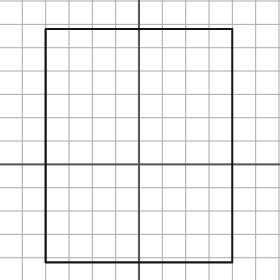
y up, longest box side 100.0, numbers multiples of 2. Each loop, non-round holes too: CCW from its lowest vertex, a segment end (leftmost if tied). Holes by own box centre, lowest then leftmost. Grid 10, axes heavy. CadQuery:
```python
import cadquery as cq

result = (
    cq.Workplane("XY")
    .moveTo(-40.0, -42.0)
    .lineTo(40.0, -42.0)
    .lineTo(40.0, 58.0)
    .lineTo(-40.0, 58.0)
    .close()
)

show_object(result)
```